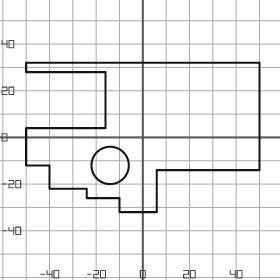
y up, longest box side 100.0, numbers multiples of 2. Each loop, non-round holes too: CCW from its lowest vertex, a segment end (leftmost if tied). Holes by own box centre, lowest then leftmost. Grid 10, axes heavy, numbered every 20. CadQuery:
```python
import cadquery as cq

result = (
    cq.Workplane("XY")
    .moveTo(-10.0, -32.0)
    .lineTo(6.0, -32.0)
    .lineTo(6.0, -14.0)
    .lineTo(50.0, -14.0)
    .lineTo(50.0, 32.0)
    .lineTo(-50.0, 32.0)
    .lineTo(-50.0, 28.0)
    .lineTo(-16.0, 28.0)
    .lineTo(-16.0, 4.0)
    .lineTo(-50.0, 4.0)
    .lineTo(-50.0, -12.0)
    .lineTo(-40.0, -12.0)
    .lineTo(-40.0, -22.0)
    .lineTo(-24.0, -22.0)
    .lineTo(-24.0, -26.0)
    .lineTo(-10.0, -26.0)
    .close()
    .moveTo(-14.0, -12.0)
    .circle(8.0)
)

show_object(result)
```